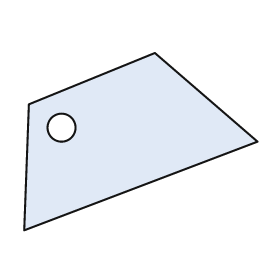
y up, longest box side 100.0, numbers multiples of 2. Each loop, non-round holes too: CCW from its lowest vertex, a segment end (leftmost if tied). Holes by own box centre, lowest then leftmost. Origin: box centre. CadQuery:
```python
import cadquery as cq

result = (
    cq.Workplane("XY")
    .moveTo(-50.0, -38.0)
    .lineTo(50.0, 0.0)
    .lineTo(6.0, 38.0)
    .lineTo(-48.0, 16.0)
    .close()
    .moveTo(-34.0, 6.0)
    .circle(6.0)
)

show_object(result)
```